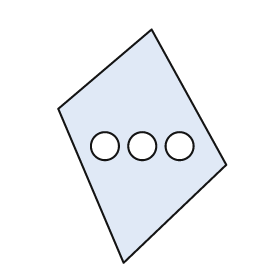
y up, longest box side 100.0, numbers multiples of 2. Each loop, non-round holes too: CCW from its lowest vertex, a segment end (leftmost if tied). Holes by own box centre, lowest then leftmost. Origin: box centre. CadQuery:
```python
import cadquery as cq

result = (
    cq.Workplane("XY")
    .moveTo(-8.0, -50.0)
    .lineTo(36.0, -8.0)
    .lineTo(4.0, 50.0)
    .lineTo(-36.0, 16.0)
    .close()
    .moveTo(-16.0, 0.0)
    .circle(6.0)
    .moveTo(0.0, 0.0)
    .circle(6.0)
    .moveTo(16.0, 0.0)
    .circle(6.0)
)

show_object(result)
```